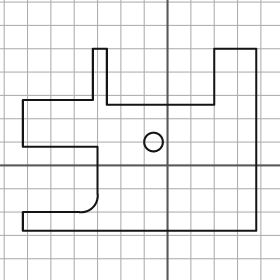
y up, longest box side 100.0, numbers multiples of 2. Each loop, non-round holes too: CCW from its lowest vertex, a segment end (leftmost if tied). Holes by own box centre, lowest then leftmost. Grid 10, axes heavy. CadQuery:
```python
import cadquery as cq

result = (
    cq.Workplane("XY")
    .moveTo(-62.0, -28.0)
    .lineTo(38.0, -28.0)
    .lineTo(38.0, 50.0)
    .lineTo(20.0, 50.0)
    .lineTo(20.0, 26.0)
    .lineTo(-26.0, 26.0)
    .lineTo(-26.0, 50.0)
    .lineTo(-32.0, 50.0)
    .lineTo(-32.0, 28.0)
    .lineTo(-62.0, 28.0)
    .lineTo(-62.0, 8.0)
    .lineTo(-30.0, 8.0)
    .lineTo(-30.0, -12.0)
    .threePointArc((-32.0, -18.0), (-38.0, -20.0))
    .lineTo(-62.0, -20.0)
    .close()
    .moveTo(-6.0, 10.0)
    .circle(4.0)
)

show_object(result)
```